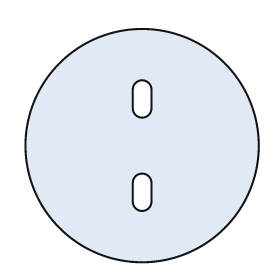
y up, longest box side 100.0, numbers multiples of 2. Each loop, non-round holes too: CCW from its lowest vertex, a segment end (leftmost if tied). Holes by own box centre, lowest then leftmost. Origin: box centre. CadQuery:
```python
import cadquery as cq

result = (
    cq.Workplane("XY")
    .moveTo(0.0, 0.0)
    .circle(50.0)
    .moveTo(-4.0, -24.0)
    .threePointArc((0.0, -28.0), (4.0, -24.0))
    .lineTo(4.0, -16.0)
    .threePointArc((0.0, -12.0), (-4.0, -16.0))
    .close()
    .moveTo(-4.0, 16.0)
    .threePointArc((0.0, 12.0), (4.0, 16.0))
    .lineTo(4.0, 24.0)
    .threePointArc((0.0, 28.0), (-4.0, 24.0))
    .close()
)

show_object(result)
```